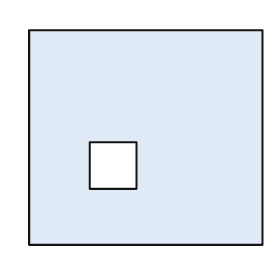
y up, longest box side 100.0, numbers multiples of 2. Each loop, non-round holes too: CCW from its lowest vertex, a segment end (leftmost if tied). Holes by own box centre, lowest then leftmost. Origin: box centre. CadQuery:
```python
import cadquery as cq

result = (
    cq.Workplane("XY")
    .moveTo(-50.0, -46.0)
    .lineTo(50.0, -46.0)
    .lineTo(50.0, 46.0)
    .lineTo(-50.0, 46.0)
    .close()
    .moveTo(-24.0, -22.0)
    .lineTo(-4.0, -22.0)
    .lineTo(-4.0, -2.0)
    .lineTo(-24.0, -2.0)
    .close()
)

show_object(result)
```